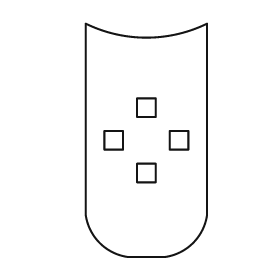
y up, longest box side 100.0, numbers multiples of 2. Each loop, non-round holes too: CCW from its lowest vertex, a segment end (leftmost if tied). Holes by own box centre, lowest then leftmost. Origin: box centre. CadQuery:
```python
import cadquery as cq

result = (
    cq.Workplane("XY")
    .moveTo(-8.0, -50.0)
    .lineTo(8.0, -50.0)
    .threePointArc((20.0, -44.0), (26.0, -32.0))
    .lineTo(26.0, 50.0)
    .threePointArc((0.0, 44.0), (-26.0, 50.0))
    .lineTo(-26.0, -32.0)
    .threePointArc((-20.0, -44.0), (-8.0, -50.0))
    .close()
    .moveTo(-4.0, -18.0)
    .lineTo(4.0, -18.0)
    .lineTo(4.0, -10.0)
    .lineTo(-4.0, -10.0)
    .close()
    .moveTo(-18.0, -4.0)
    .lineTo(-10.0, -4.0)
    .lineTo(-10.0, 4.0)
    .lineTo(-18.0, 4.0)
    .close()
    .moveTo(10.0, -4.0)
    .lineTo(18.0, -4.0)
    .lineTo(18.0, 4.0)
    .lineTo(10.0, 4.0)
    .close()
    .moveTo(-4.0, 10.0)
    .lineTo(4.0, 10.0)
    .lineTo(4.0, 18.0)
    .lineTo(-4.0, 18.0)
    .close()
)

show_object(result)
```